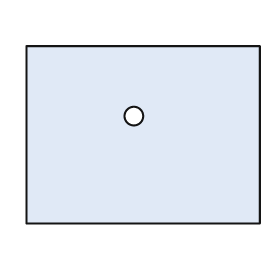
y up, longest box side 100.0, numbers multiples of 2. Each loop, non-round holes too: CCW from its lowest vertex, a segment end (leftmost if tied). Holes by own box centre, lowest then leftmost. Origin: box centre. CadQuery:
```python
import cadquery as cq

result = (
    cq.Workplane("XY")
    .moveTo(-50.0, -38.0)
    .lineTo(50.0, -38.0)
    .lineTo(50.0, 38.0)
    .lineTo(-50.0, 38.0)
    .close()
    .moveTo(-4.0, 8.0)
    .circle(4.0)
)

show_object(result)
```